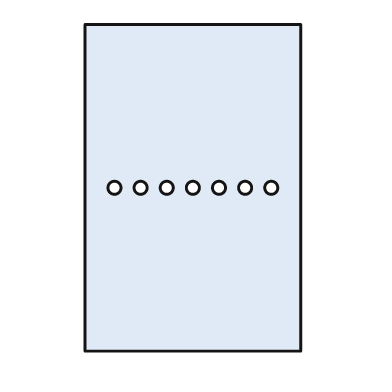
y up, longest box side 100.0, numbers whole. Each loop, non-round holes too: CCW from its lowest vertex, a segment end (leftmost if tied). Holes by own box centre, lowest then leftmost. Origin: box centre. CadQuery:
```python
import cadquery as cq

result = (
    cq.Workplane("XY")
    .moveTo(-33.0, -50.0)
    .lineTo(33.0, -50.0)
    .lineTo(33.0, 50.0)
    .lineTo(-33.0, 50.0)
    .close()
    .moveTo(-24.0, 0.0)
    .circle(2.0)
    .moveTo(-16.0, 0.0)
    .circle(2.0)
    .moveTo(-8.0, 0.0)
    .circle(2.0)
    .moveTo(0.0, 0.0)
    .circle(2.0)
    .moveTo(8.0, 0.0)
    .circle(2.0)
    .moveTo(16.0, 0.0)
    .circle(2.0)
    .moveTo(24.0, 0.0)
    .circle(2.0)
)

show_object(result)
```